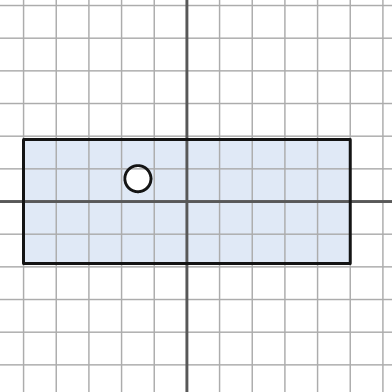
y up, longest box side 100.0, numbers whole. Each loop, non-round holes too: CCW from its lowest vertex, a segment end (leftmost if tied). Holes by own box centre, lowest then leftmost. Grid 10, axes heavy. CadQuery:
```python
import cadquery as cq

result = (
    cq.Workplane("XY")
    .moveTo(-50.0, -19.0)
    .lineTo(50.0, -19.0)
    .lineTo(50.0, 19.0)
    .lineTo(-50.0, 19.0)
    .close()
    .moveTo(-15.0, 7.0)
    .circle(4.0)
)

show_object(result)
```